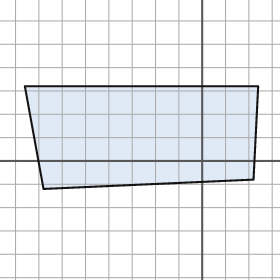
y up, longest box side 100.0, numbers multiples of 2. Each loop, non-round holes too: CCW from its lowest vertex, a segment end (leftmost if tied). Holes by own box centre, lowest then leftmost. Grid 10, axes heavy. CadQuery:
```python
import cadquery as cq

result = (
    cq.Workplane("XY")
    .moveTo(-68.0, -12.0)
    .lineTo(22.0, -8.0)
    .lineTo(24.0, 32.0)
    .lineTo(-76.0, 32.0)
    .close()
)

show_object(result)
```